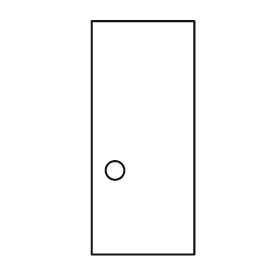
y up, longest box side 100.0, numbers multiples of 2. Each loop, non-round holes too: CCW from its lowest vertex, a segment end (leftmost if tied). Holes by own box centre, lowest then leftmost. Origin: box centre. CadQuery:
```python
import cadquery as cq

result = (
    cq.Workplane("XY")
    .moveTo(-22.0, -50.0)
    .lineTo(22.0, -50.0)
    .lineTo(22.0, 50.0)
    .lineTo(-22.0, 50.0)
    .close()
    .moveTo(-12.0, -14.0)
    .circle(4.0)
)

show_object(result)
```